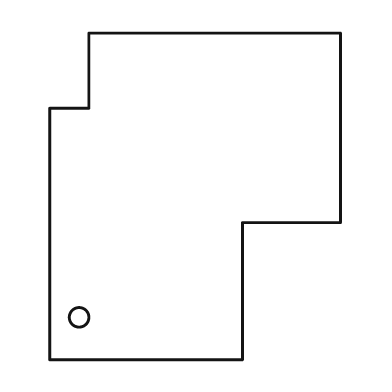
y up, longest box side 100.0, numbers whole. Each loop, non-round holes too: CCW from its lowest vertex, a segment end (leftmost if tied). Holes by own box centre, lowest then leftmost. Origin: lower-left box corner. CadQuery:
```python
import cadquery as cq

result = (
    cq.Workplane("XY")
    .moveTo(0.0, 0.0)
    .lineTo(59.0, 0.0)
    .lineTo(59.0, 42.0)
    .lineTo(89.0, 42.0)
    .lineTo(89.0, 100.0)
    .lineTo(12.0, 100.0)
    .lineTo(12.0, 77.0)
    .lineTo(0.0, 77.0)
    .close()
    .moveTo(9.0, 13.0)
    .circle(3.0)
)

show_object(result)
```